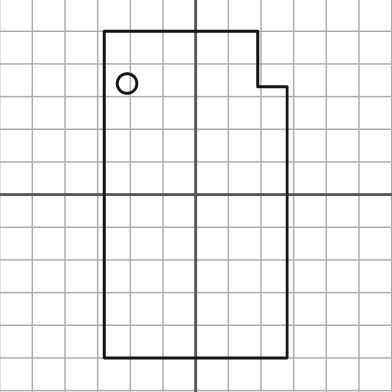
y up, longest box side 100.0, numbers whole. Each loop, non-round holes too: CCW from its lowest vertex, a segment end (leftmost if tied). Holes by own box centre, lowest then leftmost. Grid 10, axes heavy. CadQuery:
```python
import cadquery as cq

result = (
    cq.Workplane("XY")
    .moveTo(-28.0, -50.0)
    .lineTo(28.0, -50.0)
    .lineTo(28.0, 33.0)
    .lineTo(19.0, 33.0)
    .lineTo(19.0, 50.0)
    .lineTo(-28.0, 50.0)
    .close()
    .moveTo(-21.0, 34.0)
    .circle(3.0)
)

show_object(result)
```